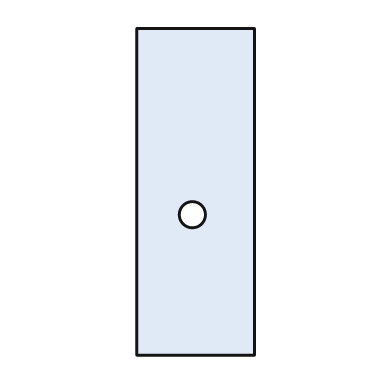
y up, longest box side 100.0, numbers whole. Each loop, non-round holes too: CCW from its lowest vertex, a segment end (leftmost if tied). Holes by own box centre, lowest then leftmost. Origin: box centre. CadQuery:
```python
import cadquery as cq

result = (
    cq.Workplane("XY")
    .moveTo(-18.0, -50.0)
    .lineTo(18.0, -50.0)
    .lineTo(18.0, 50.0)
    .lineTo(-18.0, 50.0)
    .close()
    .moveTo(-1.0, -7.0)
    .circle(4.0)
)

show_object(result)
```